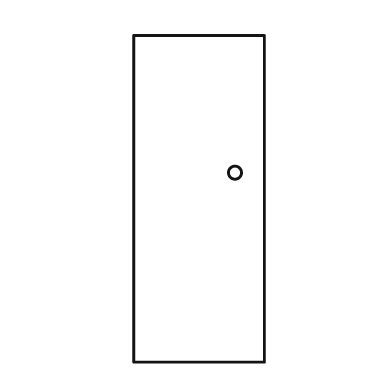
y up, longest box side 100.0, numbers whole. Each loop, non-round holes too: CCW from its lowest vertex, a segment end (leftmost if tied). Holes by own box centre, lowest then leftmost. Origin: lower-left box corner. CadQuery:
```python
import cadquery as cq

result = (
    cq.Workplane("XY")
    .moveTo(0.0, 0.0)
    .lineTo(40.0, 0.0)
    .lineTo(40.0, 100.0)
    .lineTo(0.0, 100.0)
    .close()
    .moveTo(31.0, 58.0)
    .circle(2.0)
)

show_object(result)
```